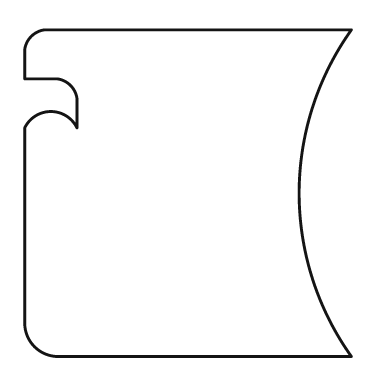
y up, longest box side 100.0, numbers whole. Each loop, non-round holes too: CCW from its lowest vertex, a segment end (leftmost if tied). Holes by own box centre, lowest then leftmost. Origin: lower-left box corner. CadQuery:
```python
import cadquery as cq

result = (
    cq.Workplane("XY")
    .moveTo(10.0, 0.0)
    .lineTo(100.0, 0.0)
    .threePointArc((84.0, 50.0), (100.0, 100.0))
    .lineTo(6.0, 100.0)
    .threePointArc((2.0, 98.0), (0.0, 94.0))
    .lineTo(0.0, 85.0)
    .lineTo(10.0, 85.0)
    .threePointArc((14.0, 83.0), (16.0, 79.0))
    .lineTo(16.0, 70.0)
    .threePointArc((8.0, 75.0), (0.0, 70.0))
    .lineTo(0.0, 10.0)
    .threePointArc((3.0, 3.0), (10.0, 0.0))
    .close()
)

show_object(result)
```